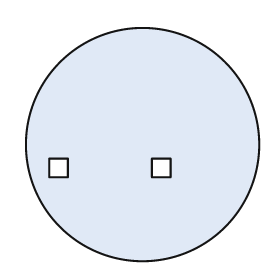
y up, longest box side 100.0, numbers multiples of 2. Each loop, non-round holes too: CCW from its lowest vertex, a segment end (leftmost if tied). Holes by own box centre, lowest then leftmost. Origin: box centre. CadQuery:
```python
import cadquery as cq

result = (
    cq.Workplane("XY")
    .moveTo(0.0, 0.0)
    .circle(50.0)
    .moveTo(-40.0, -14.0)
    .lineTo(-32.0, -14.0)
    .lineTo(-32.0, -6.0)
    .lineTo(-40.0, -6.0)
    .close()
    .moveTo(4.0, -14.0)
    .lineTo(12.0, -14.0)
    .lineTo(12.0, -6.0)
    .lineTo(4.0, -6.0)
    .close()
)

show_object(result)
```